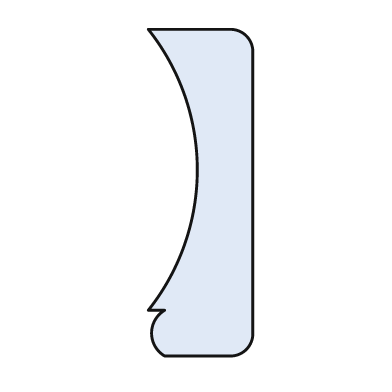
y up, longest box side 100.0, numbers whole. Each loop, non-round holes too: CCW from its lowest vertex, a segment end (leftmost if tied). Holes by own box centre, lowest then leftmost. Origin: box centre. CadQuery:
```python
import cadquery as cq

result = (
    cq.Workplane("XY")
    .moveTo(-11.0, -50.0)
    .lineTo(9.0, -50.0)
    .threePointArc((14.0, -48.0), (16.0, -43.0))
    .lineTo(16.0, 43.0)
    .threePointArc((14.0, 48.0), (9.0, 50.0))
    .lineTo(-16.0, 50.0)
    .threePointArc((-1.0, 7.0), (-16.0, -36.0))
    .lineTo(-11.0, -36.0)
    .threePointArc((-15.0, -43.0), (-11.0, -50.0))
    .close()
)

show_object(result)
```